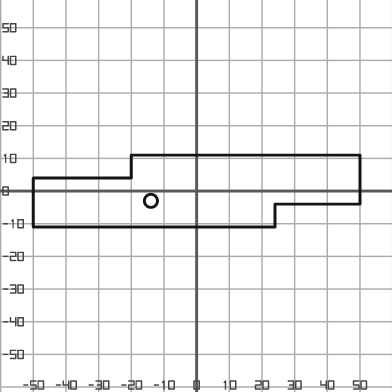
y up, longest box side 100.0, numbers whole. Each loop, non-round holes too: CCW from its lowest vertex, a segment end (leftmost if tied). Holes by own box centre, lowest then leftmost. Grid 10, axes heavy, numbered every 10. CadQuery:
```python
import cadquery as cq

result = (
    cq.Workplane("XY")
    .moveTo(-50.0, -11.0)
    .lineTo(24.0, -11.0)
    .lineTo(24.0, -4.0)
    .lineTo(50.0, -4.0)
    .lineTo(50.0, 11.0)
    .lineTo(-20.0, 11.0)
    .lineTo(-20.0, 4.0)
    .lineTo(-50.0, 4.0)
    .close()
    .moveTo(-14.0, -3.0)
    .circle(2.0)
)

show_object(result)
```